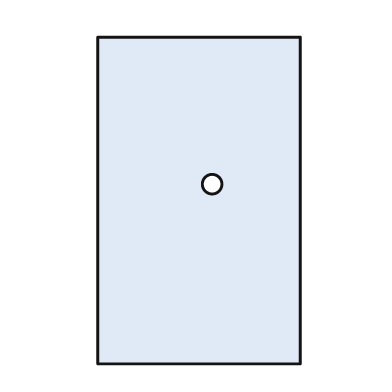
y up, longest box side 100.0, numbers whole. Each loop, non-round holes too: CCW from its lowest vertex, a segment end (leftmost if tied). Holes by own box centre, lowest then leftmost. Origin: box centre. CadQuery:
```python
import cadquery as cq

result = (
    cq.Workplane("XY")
    .moveTo(-31.0, -50.0)
    .lineTo(31.0, -50.0)
    .lineTo(31.0, 50.0)
    .lineTo(-31.0, 50.0)
    .close()
    .moveTo(4.0, 5.0)
    .circle(3.0)
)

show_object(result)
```